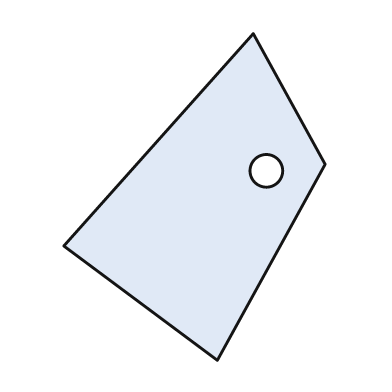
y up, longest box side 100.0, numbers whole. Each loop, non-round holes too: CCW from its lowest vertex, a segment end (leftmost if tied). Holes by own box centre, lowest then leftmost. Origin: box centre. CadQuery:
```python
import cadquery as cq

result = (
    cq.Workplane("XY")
    .moveTo(7.0, -50.0)
    .lineTo(40.0, 10.0)
    .lineTo(18.0, 50.0)
    .lineTo(-40.0, -15.0)
    .close()
    .moveTo(22.0, 8.0)
    .circle(5.0)
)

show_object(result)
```